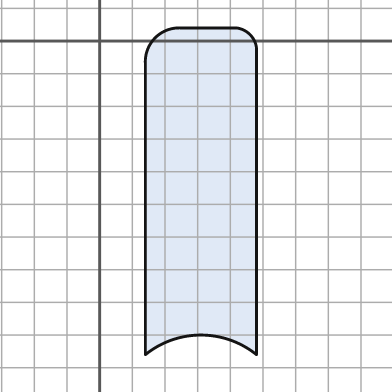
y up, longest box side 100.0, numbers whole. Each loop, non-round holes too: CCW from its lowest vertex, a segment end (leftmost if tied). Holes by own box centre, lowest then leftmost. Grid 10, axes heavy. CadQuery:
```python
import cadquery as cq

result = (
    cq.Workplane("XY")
    .moveTo(14.0, -96.0)
    .threePointArc((31.0, -90.0), (48.0, -96.0))
    .lineTo(48.0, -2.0)
    .threePointArc((46.0, 2.0), (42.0, 4.0))
    .lineTo(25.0, 4.0)
    .threePointArc((17.0, 1.0), (14.0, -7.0))
    .close()
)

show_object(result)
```